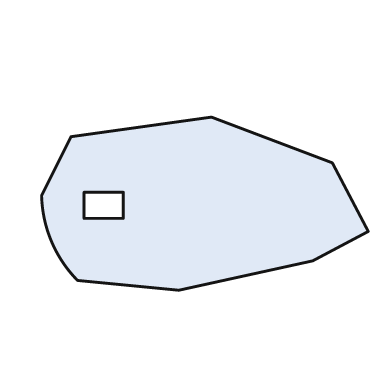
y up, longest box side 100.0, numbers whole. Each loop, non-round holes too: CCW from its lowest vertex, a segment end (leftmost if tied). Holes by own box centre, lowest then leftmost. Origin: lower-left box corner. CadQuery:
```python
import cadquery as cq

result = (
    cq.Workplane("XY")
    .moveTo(42.0, 0.0)
    .lineTo(83.0, 9.0)
    .lineTo(100.0, 18.0)
    .lineTo(89.0, 39.0)
    .lineTo(52.0, 53.0)
    .lineTo(9.0, 47.0)
    .lineTo(0.0, 29.0)
    .threePointArc((3.0, 15.0), (11.0, 3.0))
    .close()
    .moveTo(13.0, 22.0)
    .lineTo(25.0, 22.0)
    .lineTo(25.0, 30.0)
    .lineTo(13.0, 30.0)
    .close()
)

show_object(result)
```